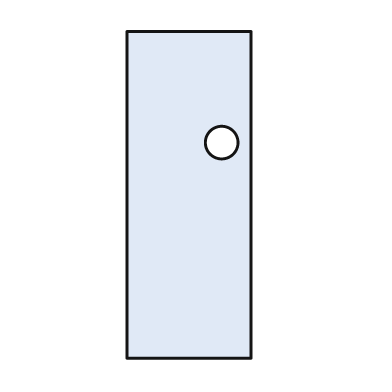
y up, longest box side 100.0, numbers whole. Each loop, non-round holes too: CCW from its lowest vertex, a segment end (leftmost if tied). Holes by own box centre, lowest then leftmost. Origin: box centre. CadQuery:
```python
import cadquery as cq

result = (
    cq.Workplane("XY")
    .moveTo(-19.0, -50.0)
    .lineTo(19.0, -50.0)
    .lineTo(19.0, 50.0)
    .lineTo(-19.0, 50.0)
    .close()
    .moveTo(10.0, 16.0)
    .circle(5.0)
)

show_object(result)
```